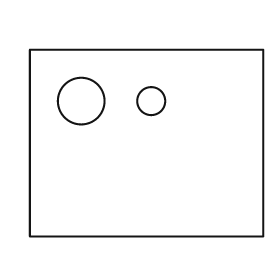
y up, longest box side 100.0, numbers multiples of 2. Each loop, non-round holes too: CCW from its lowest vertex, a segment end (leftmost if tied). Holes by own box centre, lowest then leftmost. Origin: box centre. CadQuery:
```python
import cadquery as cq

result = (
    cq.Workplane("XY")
    .moveTo(-50.0, -40.0)
    .lineTo(50.0, -40.0)
    .lineTo(50.0, 40.0)
    .lineTo(-50.0, 40.0)
    .close()
    .moveTo(-28.0, 18.0)
    .circle(10.0)
    .moveTo(2.0, 18.0)
    .circle(6.0)
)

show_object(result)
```